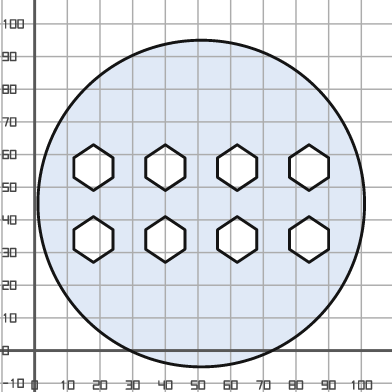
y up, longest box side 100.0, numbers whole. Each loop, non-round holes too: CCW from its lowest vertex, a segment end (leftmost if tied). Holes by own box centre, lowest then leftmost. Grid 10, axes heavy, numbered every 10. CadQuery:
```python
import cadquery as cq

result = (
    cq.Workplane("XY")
    .moveTo(51.0, 45.0)
    .circle(50.0)
    .moveTo(18.0, 27.0)
    .lineTo(24.0, 31.0)
    .lineTo(24.0, 37.0)
    .lineTo(18.0, 41.0)
    .lineTo(12.0, 37.0)
    .lineTo(12.0, 31.0)
    .close()
    .moveTo(40.0, 27.0)
    .lineTo(46.0, 31.0)
    .lineTo(46.0, 37.0)
    .lineTo(40.0, 41.0)
    .lineTo(34.0, 37.0)
    .lineTo(34.0, 31.0)
    .close()
    .moveTo(62.0, 27.0)
    .lineTo(68.0, 31.0)
    .lineTo(68.0, 37.0)
    .lineTo(62.0, 41.0)
    .lineTo(56.0, 37.0)
    .lineTo(56.0, 31.0)
    .close()
    .moveTo(84.0, 27.0)
    .lineTo(90.0, 31.0)
    .lineTo(90.0, 37.0)
    .lineTo(84.0, 41.0)
    .lineTo(78.0, 37.0)
    .lineTo(78.0, 31.0)
    .close()
    .moveTo(18.0, 49.0)
    .lineTo(24.0, 53.0)
    .lineTo(24.0, 59.0)
    .lineTo(18.0, 63.0)
    .lineTo(12.0, 59.0)
    .lineTo(12.0, 53.0)
    .close()
    .moveTo(40.0, 49.0)
    .lineTo(46.0, 53.0)
    .lineTo(46.0, 59.0)
    .lineTo(40.0, 63.0)
    .lineTo(34.0, 59.0)
    .lineTo(34.0, 53.0)
    .close()
    .moveTo(62.0, 49.0)
    .lineTo(68.0, 53.0)
    .lineTo(68.0, 59.0)
    .lineTo(62.0, 63.0)
    .lineTo(56.0, 59.0)
    .lineTo(56.0, 53.0)
    .close()
    .moveTo(84.0, 49.0)
    .lineTo(90.0, 53.0)
    .lineTo(90.0, 59.0)
    .lineTo(84.0, 63.0)
    .lineTo(78.0, 59.0)
    .lineTo(78.0, 53.0)
    .close()
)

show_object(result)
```